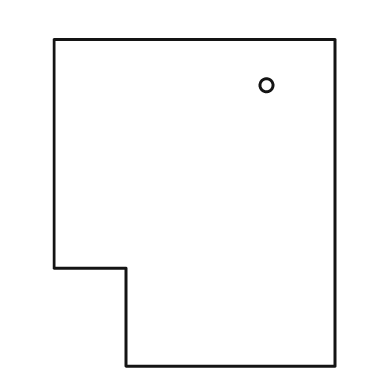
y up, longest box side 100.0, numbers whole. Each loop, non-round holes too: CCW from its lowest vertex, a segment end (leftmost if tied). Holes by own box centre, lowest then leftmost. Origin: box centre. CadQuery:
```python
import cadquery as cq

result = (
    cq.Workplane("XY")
    .moveTo(-21.0, -50.0)
    .lineTo(43.0, -50.0)
    .lineTo(43.0, 50.0)
    .lineTo(-43.0, 50.0)
    .lineTo(-43.0, -20.0)
    .lineTo(-21.0, -20.0)
    .close()
    .moveTo(22.0, 36.0)
    .circle(2.0)
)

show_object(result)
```